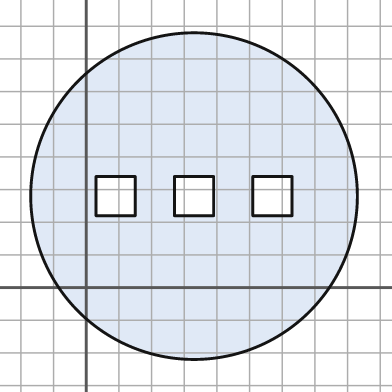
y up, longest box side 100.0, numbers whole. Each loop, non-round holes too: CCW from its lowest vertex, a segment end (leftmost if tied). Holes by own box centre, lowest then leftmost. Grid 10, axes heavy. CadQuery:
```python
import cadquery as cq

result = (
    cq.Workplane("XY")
    .moveTo(33.0, 28.0)
    .circle(50.0)
    .moveTo(3.0, 22.0)
    .lineTo(15.0, 22.0)
    .lineTo(15.0, 34.0)
    .lineTo(3.0, 34.0)
    .close()
    .moveTo(27.0, 22.0)
    .lineTo(39.0, 22.0)
    .lineTo(39.0, 34.0)
    .lineTo(27.0, 34.0)
    .close()
    .moveTo(51.0, 22.0)
    .lineTo(63.0, 22.0)
    .lineTo(63.0, 34.0)
    .lineTo(51.0, 34.0)
    .close()
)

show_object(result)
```